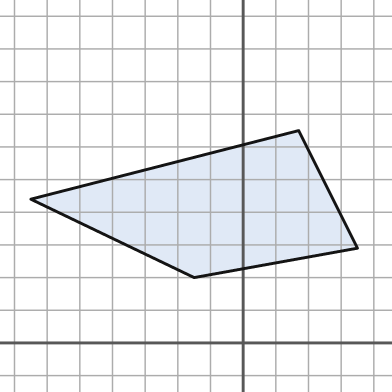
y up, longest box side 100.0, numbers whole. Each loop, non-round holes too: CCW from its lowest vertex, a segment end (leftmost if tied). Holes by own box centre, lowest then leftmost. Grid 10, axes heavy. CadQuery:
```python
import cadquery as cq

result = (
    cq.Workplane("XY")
    .moveTo(-15.0, 20.0)
    .lineTo(35.0, 29.0)
    .lineTo(17.0, 65.0)
    .lineTo(-65.0, 44.0)
    .close()
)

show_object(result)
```